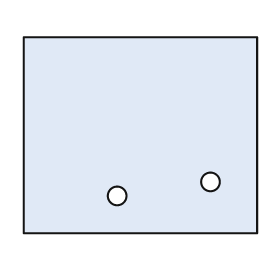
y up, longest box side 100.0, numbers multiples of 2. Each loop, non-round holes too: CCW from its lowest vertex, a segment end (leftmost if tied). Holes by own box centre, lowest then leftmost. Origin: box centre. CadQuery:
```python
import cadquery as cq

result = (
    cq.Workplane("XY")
    .moveTo(-50.0, -42.0)
    .lineTo(50.0, -42.0)
    .lineTo(50.0, 42.0)
    .lineTo(-50.0, 42.0)
    .close()
    .moveTo(-10.0, -26.0)
    .circle(4.0)
    .moveTo(30.0, -20.0)
    .circle(4.0)
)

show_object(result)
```